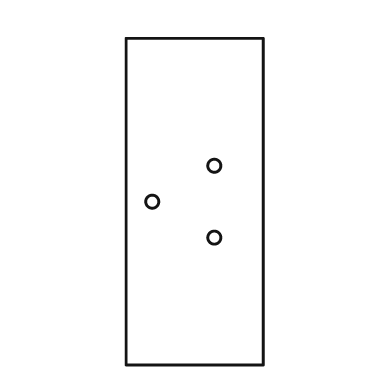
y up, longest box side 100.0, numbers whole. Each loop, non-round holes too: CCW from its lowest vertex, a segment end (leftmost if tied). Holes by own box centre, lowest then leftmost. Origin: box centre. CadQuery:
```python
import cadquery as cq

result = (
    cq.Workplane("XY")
    .moveTo(-21.0, -50.0)
    .lineTo(21.0, -50.0)
    .lineTo(21.0, 50.0)
    .lineTo(-21.0, 50.0)
    .close()
    .moveTo(6.0, -11.0)
    .circle(2.0)
    .moveTo(-13.0, 0.0)
    .circle(2.0)
    .moveTo(6.0, 11.0)
    .circle(2.0)
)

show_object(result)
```